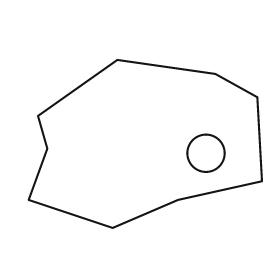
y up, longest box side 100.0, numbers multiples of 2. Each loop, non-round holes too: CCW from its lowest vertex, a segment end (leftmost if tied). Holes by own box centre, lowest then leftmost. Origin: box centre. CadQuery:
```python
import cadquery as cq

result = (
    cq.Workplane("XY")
    .moveTo(-14.0, -36.0)
    .lineTo(14.0, -24.0)
    .lineTo(50.0, -16.0)
    .lineTo(48.0, 20.0)
    .lineTo(30.0, 30.0)
    .lineTo(-12.0, 36.0)
    .lineTo(-46.0, 12.0)
    .lineTo(-42.0, -2.0)
    .lineTo(-50.0, -24.0)
    .close()
    .moveTo(26.0, -4.0)
    .circle(8.0)
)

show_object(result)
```